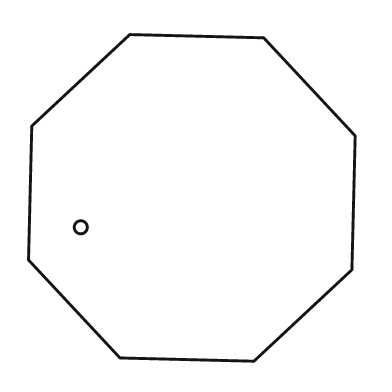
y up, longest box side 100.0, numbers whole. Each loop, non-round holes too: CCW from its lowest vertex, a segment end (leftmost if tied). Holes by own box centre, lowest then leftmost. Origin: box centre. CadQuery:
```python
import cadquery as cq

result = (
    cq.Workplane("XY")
    .moveTo(19.0, -50.0)
    .lineTo(49.0, -22.0)
    .lineTo(50.0, 19.0)
    .lineTo(22.0, 49.0)
    .lineTo(-19.0, 50.0)
    .lineTo(-49.0, 22.0)
    .lineTo(-50.0, -19.0)
    .lineTo(-22.0, -49.0)
    .close()
    .moveTo(-34.0, -9.0)
    .circle(2.0)
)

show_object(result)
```